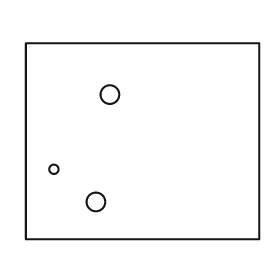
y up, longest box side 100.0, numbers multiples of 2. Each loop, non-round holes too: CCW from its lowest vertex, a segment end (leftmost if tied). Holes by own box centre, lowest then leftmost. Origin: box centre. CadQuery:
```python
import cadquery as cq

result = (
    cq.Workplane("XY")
    .moveTo(-50.0, -42.0)
    .lineTo(50.0, -42.0)
    .lineTo(50.0, 42.0)
    .lineTo(-50.0, 42.0)
    .close()
    .moveTo(-20.0, -26.0)
    .circle(4.0)
    .moveTo(-38.0, -12.0)
    .circle(2.0)
    .moveTo(-14.0, 20.0)
    .circle(4.0)
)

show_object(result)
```